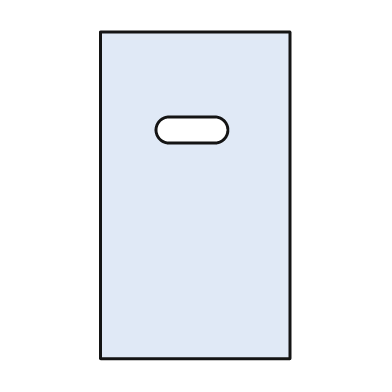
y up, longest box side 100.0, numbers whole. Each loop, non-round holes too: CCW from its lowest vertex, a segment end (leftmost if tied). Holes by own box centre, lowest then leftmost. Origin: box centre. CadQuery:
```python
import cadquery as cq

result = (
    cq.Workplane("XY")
    .moveTo(-29.0, -50.0)
    .lineTo(29.0, -50.0)
    .lineTo(29.0, 50.0)
    .lineTo(-29.0, 50.0)
    .close()
    .moveTo(-8.0, 16.0)
    .lineTo(6.0, 16.0)
    .threePointArc((10.0, 20.0), (6.0, 24.0))
    .lineTo(-8.0, 24.0)
    .threePointArc((-12.0, 20.0), (-8.0, 16.0))
    .close()
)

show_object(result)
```